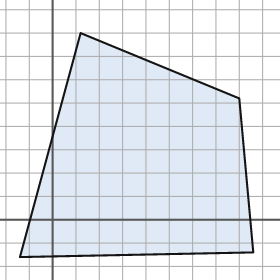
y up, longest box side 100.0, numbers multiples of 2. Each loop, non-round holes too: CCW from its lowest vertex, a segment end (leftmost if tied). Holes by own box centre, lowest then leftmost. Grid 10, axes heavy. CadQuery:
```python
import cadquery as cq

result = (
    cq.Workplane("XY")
    .moveTo(-14.0, -16.0)
    .lineTo(86.0, -14.0)
    .lineTo(80.0, 52.0)
    .lineTo(12.0, 80.0)
    .close()
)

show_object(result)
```